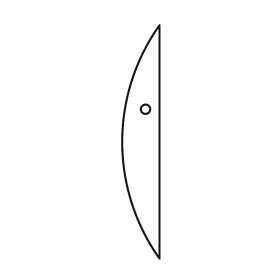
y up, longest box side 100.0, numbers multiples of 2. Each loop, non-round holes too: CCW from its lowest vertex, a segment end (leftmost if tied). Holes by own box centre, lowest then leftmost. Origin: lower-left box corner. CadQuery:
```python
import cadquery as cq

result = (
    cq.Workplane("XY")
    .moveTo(16.0, 0.0)
    .lineTo(16.0, 100.0)
    .threePointArc((0.0, 50.0), (16.0, 0.0))
    .close()
    .moveTo(10.0, 64.0)
    .circle(2.0)
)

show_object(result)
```